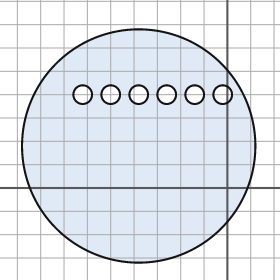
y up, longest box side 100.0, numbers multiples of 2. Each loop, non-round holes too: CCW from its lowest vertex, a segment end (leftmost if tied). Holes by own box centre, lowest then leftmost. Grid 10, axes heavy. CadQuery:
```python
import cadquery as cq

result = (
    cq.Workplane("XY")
    .moveTo(-38.0, 18.0)
    .circle(50.0)
    .moveTo(-62.0, 40.0)
    .circle(4.0)
    .moveTo(-50.0, 40.0)
    .circle(4.0)
    .moveTo(-38.0, 40.0)
    .circle(4.0)
    .moveTo(-26.0, 40.0)
    .circle(4.0)
    .moveTo(-14.0, 40.0)
    .circle(4.0)
    .moveTo(-2.0, 40.0)
    .circle(4.0)
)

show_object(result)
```